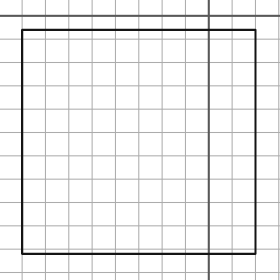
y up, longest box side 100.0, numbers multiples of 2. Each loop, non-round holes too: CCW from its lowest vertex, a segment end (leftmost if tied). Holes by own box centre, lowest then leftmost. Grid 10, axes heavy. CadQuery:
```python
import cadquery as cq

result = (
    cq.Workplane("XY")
    .moveTo(-80.0, -102.0)
    .lineTo(20.0, -102.0)
    .lineTo(20.0, -6.0)
    .lineTo(-80.0, -6.0)
    .close()
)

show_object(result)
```